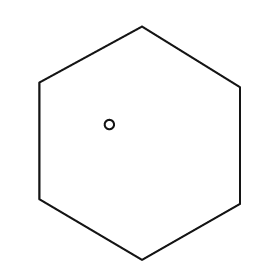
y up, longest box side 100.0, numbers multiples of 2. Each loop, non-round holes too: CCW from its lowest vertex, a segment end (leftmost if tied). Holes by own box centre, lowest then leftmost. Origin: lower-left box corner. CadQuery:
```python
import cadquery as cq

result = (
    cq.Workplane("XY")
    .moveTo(44.0, 0.0)
    .lineTo(86.0, 24.0)
    .lineTo(86.0, 74.0)
    .lineTo(44.0, 100.0)
    .lineTo(0.0, 76.0)
    .lineTo(0.0, 26.0)
    .close()
    .moveTo(30.0, 58.0)
    .circle(2.0)
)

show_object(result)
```